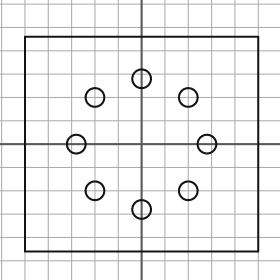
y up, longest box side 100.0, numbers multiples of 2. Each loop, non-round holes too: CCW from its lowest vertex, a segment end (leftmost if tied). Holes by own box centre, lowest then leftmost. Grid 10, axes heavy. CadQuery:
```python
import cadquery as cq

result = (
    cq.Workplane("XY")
    .moveTo(-50.0, -46.0)
    .lineTo(50.0, -46.0)
    .lineTo(50.0, 46.0)
    .lineTo(-50.0, 46.0)
    .close()
    .moveTo(0.0, -28.0)
    .circle(4.0)
    .moveTo(-20.0, -20.0)
    .circle(4.0)
    .moveTo(20.0, -20.0)
    .circle(4.0)
    .moveTo(-28.0, 0.0)
    .circle(4.0)
    .moveTo(28.0, 0.0)
    .circle(4.0)
    .moveTo(-20.0, 20.0)
    .circle(4.0)
    .moveTo(20.0, 20.0)
    .circle(4.0)
    .moveTo(0.0, 28.0)
    .circle(4.0)
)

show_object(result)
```